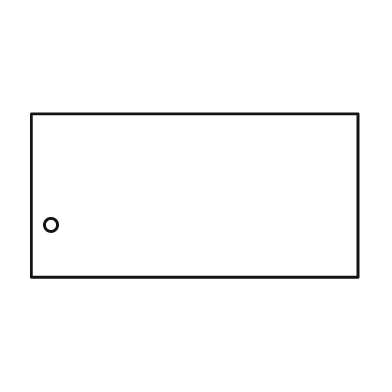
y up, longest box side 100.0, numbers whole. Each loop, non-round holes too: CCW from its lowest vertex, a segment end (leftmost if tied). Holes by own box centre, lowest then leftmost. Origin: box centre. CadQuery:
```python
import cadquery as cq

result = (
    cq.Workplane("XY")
    .moveTo(-50.0, -25.0)
    .lineTo(50.0, -25.0)
    .lineTo(50.0, 25.0)
    .lineTo(-50.0, 25.0)
    .close()
    .moveTo(-44.0, -9.0)
    .circle(2.0)
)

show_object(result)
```